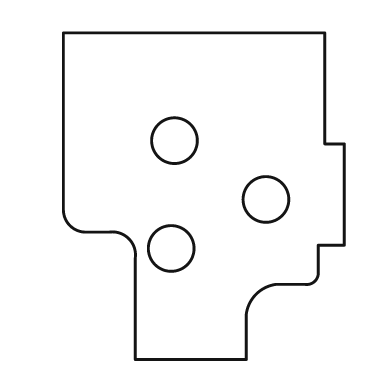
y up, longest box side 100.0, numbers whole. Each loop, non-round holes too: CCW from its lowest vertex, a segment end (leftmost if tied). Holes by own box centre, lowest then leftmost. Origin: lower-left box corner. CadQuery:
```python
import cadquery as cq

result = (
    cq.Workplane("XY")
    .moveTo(22.0, 0.0)
    .lineTo(56.0, 0.0)
    .lineTo(56.0, 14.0)
    .threePointArc((59.0, 20.0), (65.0, 23.0))
    .lineTo(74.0, 23.0)
    .threePointArc((77.0, 24.0), (78.0, 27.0))
    .lineTo(78.0, 35.0)
    .lineTo(86.0, 35.0)
    .lineTo(86.0, 66.0)
    .lineTo(80.0, 66.0)
    .lineTo(80.0, 100.0)
    .lineTo(0.0, 100.0)
    .lineTo(0.0, 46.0)
    .threePointArc((2.0, 41.0), (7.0, 39.0))
    .lineTo(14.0, 39.0)
    .threePointArc((20.0, 37.0), (22.0, 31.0))
    .close()
    .moveTo(33.0, 34.0)
    .circle(7.0)
    .moveTo(62.0, 49.0)
    .circle(7.0)
    .moveTo(34.0, 67.0)
    .circle(7.0)
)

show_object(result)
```